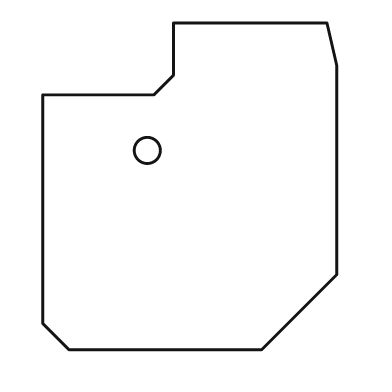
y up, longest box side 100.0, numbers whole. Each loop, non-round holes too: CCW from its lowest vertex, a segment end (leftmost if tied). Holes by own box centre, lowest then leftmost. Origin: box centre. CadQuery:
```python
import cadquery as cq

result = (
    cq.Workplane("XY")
    .moveTo(-37.0, -50.0)
    .lineTo(22.0, -50.0)
    .lineTo(45.0, -27.0)
    .lineTo(45.0, 37.0)
    .lineTo(42.0, 50.0)
    .lineTo(-5.0, 50.0)
    .lineTo(-5.0, 34.0)
    .lineTo(-11.0, 28.0)
    .lineTo(-45.0, 28.0)
    .lineTo(-45.0, -42.0)
    .close()
    .moveTo(-13.0, 11.0)
    .circle(4.0)
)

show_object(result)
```